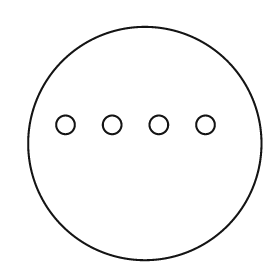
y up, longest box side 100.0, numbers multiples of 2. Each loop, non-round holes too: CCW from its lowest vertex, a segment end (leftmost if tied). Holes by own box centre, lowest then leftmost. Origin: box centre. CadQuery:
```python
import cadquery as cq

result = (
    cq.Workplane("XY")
    .moveTo(0.0, 0.0)
    .circle(50.0)
    .moveTo(-34.0, 8.0)
    .circle(4.0)
    .moveTo(-14.0, 8.0)
    .circle(4.0)
    .moveTo(6.0, 8.0)
    .circle(4.0)
    .moveTo(26.0, 8.0)
    .circle(4.0)
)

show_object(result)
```